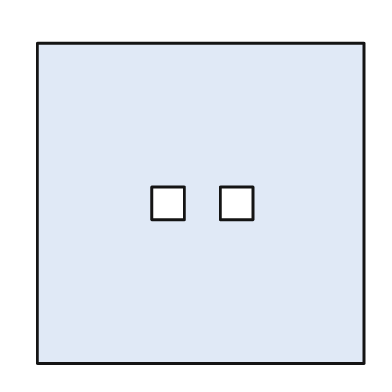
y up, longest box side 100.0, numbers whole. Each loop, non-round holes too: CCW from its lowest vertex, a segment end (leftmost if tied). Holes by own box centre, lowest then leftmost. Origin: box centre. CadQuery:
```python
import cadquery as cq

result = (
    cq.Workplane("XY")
    .moveTo(-50.0, -49.0)
    .lineTo(50.0, -49.0)
    .lineTo(50.0, 49.0)
    .lineTo(-50.0, 49.0)
    .close()
    .moveTo(-15.0, -5.0)
    .lineTo(-5.0, -5.0)
    .lineTo(-5.0, 5.0)
    .lineTo(-15.0, 5.0)
    .close()
    .moveTo(6.0, -5.0)
    .lineTo(16.0, -5.0)
    .lineTo(16.0, 5.0)
    .lineTo(6.0, 5.0)
    .close()
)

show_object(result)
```